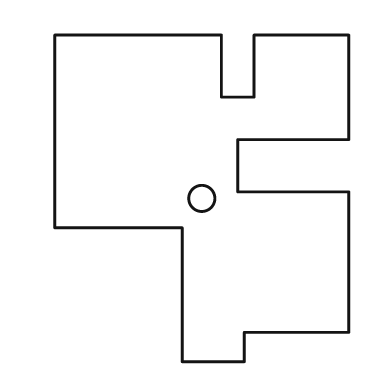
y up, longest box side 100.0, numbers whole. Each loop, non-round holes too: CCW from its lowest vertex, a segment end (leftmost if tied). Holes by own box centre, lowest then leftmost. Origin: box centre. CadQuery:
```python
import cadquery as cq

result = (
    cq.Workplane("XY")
    .moveTo(-6.0, -50.0)
    .lineTo(13.0, -50.0)
    .lineTo(13.0, -41.0)
    .lineTo(45.0, -41.0)
    .lineTo(45.0, 2.0)
    .lineTo(11.0, 2.0)
    .lineTo(11.0, 18.0)
    .lineTo(45.0, 18.0)
    .lineTo(45.0, 50.0)
    .lineTo(16.0, 50.0)
    .lineTo(16.0, 31.0)
    .lineTo(6.0, 31.0)
    .lineTo(6.0, 50.0)
    .lineTo(-45.0, 50.0)
    .lineTo(-45.0, -9.0)
    .lineTo(-6.0, -9.0)
    .close()
    .moveTo(0.0, 0.0)
    .circle(4.0)
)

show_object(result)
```